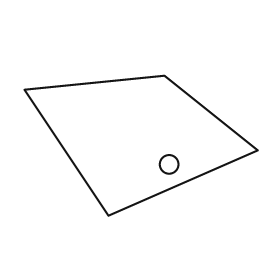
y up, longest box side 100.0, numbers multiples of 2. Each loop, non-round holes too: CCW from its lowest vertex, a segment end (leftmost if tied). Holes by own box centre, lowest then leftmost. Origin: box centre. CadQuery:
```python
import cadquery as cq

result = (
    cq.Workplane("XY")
    .moveTo(-14.0, -30.0)
    .lineTo(50.0, -2.0)
    .lineTo(10.0, 30.0)
    .lineTo(-50.0, 24.0)
    .close()
    .moveTo(12.0, -8.0)
    .circle(4.0)
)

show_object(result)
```